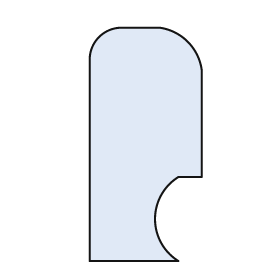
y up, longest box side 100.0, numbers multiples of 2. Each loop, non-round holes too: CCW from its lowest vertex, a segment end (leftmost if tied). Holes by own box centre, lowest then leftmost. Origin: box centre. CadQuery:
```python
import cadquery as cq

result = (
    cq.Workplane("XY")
    .moveTo(-24.0, -50.0)
    .lineTo(14.0, -50.0)
    .threePointArc((4.0, -32.0), (14.0, -14.0))
    .lineTo(24.0, -14.0)
    .lineTo(24.0, 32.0)
    .threePointArc((18.0, 44.0), (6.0, 50.0))
    .lineTo(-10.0, 50.0)
    .threePointArc((-20.0, 46.0), (-24.0, 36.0))
    .close()
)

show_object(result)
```